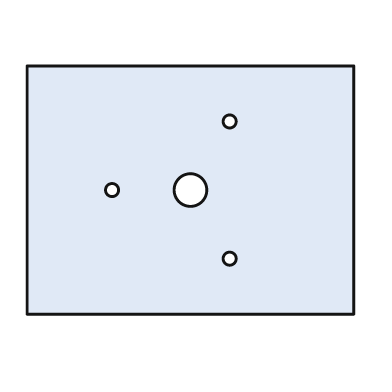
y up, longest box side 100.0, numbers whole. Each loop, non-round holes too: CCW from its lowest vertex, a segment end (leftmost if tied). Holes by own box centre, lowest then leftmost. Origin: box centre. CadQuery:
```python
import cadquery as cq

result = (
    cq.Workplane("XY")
    .moveTo(-50.0, -38.0)
    .lineTo(50.0, -38.0)
    .lineTo(50.0, 38.0)
    .lineTo(-50.0, 38.0)
    .close()
    .moveTo(12.0, -21.0)
    .circle(2.0)
    .moveTo(-24.0, 0.0)
    .circle(2.0)
    .moveTo(0.0, 0.0)
    .circle(5.0)
    .moveTo(12.0, 21.0)
    .circle(2.0)
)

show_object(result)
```